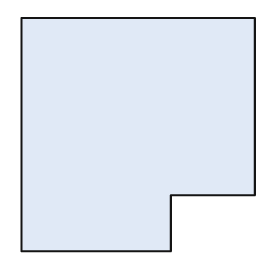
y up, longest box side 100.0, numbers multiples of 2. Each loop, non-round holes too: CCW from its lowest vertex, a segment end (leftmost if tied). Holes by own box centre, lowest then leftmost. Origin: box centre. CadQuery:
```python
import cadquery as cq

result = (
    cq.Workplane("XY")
    .moveTo(-50.0, -50.0)
    .lineTo(14.0, -50.0)
    .lineTo(14.0, -26.0)
    .lineTo(50.0, -26.0)
    .lineTo(50.0, 50.0)
    .lineTo(-50.0, 50.0)
    .close()
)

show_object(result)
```